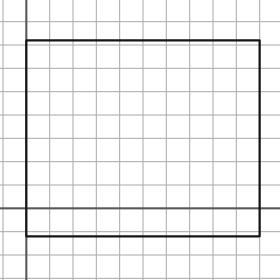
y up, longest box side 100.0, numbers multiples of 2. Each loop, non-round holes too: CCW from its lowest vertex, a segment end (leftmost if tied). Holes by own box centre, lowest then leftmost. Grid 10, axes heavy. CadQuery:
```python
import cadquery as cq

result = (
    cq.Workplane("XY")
    .moveTo(0.0, -12.0)
    .lineTo(100.0, -12.0)
    .lineTo(100.0, 72.0)
    .lineTo(0.0, 72.0)
    .close()
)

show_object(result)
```